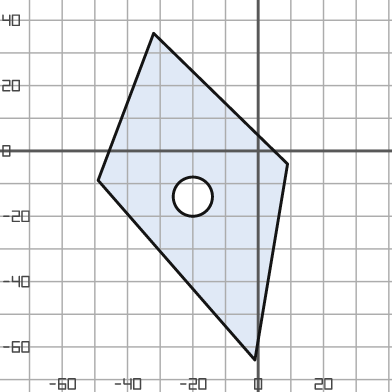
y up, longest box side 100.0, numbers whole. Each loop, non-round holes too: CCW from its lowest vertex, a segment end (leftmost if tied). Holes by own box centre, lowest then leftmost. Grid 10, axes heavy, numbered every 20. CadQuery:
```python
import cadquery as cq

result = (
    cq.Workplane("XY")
    .moveTo(-1.0, -64.0)
    .lineTo(9.0, -4.0)
    .lineTo(-32.0, 36.0)
    .lineTo(-49.0, -9.0)
    .close()
    .moveTo(-20.0, -14.0)
    .circle(6.0)
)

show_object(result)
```